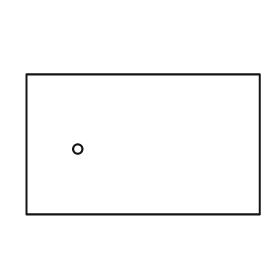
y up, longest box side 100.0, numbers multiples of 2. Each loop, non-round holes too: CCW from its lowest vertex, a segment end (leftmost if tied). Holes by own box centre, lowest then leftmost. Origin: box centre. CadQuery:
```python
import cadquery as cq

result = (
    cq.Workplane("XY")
    .moveTo(-50.0, -30.0)
    .lineTo(50.0, -30.0)
    .lineTo(50.0, 30.0)
    .lineTo(-50.0, 30.0)
    .close()
    .moveTo(-28.0, -2.0)
    .circle(2.0)
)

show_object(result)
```